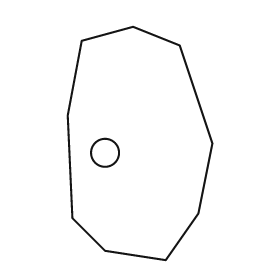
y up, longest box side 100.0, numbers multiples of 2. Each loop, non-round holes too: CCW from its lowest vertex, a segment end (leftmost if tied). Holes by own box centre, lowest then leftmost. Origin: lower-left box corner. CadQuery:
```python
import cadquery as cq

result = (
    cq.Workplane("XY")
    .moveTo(42.0, 0.0)
    .lineTo(56.0, 20.0)
    .lineTo(62.0, 50.0)
    .lineTo(48.0, 92.0)
    .lineTo(28.0, 100.0)
    .lineTo(6.0, 94.0)
    .lineTo(0.0, 62.0)
    .lineTo(2.0, 18.0)
    .lineTo(16.0, 4.0)
    .close()
    .moveTo(16.0, 46.0)
    .circle(6.0)
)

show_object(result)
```